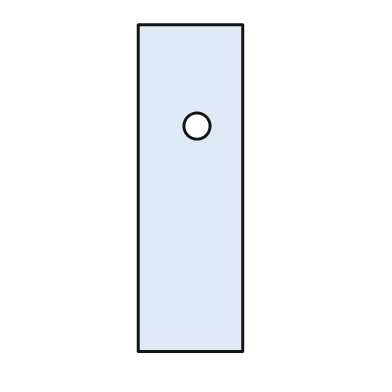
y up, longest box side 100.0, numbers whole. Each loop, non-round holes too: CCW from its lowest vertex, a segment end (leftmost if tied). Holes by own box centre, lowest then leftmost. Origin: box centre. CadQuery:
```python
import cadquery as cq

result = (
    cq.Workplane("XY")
    .moveTo(-16.0, -50.0)
    .lineTo(16.0, -50.0)
    .lineTo(16.0, 50.0)
    .lineTo(-16.0, 50.0)
    .close()
    .moveTo(2.0, 19.0)
    .circle(4.0)
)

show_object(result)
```